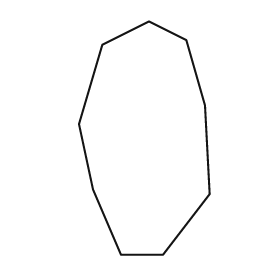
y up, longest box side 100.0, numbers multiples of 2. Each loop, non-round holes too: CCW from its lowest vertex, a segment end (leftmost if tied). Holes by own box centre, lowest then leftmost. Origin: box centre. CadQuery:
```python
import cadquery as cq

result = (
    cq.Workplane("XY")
    .moveTo(-10.0, -50.0)
    .lineTo(8.0, -50.0)
    .lineTo(28.0, -24.0)
    .lineTo(26.0, 14.0)
    .lineTo(18.0, 42.0)
    .lineTo(2.0, 50.0)
    .lineTo(-18.0, 40.0)
    .lineTo(-28.0, 6.0)
    .lineTo(-22.0, -22.0)
    .close()
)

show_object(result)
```